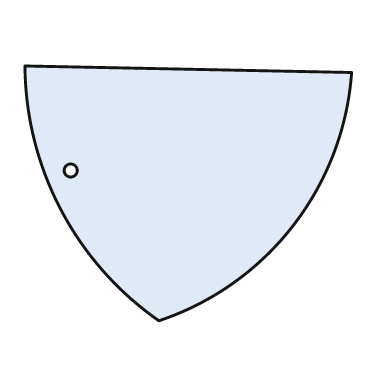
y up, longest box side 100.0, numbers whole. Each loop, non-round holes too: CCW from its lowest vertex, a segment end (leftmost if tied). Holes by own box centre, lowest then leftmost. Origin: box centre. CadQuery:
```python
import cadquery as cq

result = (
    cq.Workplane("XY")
    .moveTo(-9.0, -39.0)
    .threePointArc((32.0, -10.0), (50.0, 37.0))
    .lineTo(-50.0, 39.0)
    .threePointArc((-39.0, -5.0), (-9.0, -39.0))
    .close()
    .moveTo(-36.0, 7.0)
    .circle(2.0)
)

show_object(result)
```